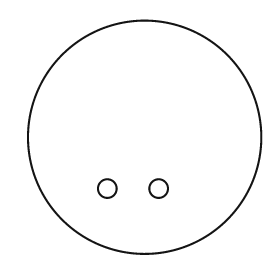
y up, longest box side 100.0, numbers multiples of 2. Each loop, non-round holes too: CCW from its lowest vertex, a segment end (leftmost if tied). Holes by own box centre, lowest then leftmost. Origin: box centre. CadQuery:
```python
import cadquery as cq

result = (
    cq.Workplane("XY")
    .moveTo(0.0, 0.0)
    .circle(50.0)
    .moveTo(-16.0, -22.0)
    .circle(4.0)
    .moveTo(6.0, -22.0)
    .circle(4.0)
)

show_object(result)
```